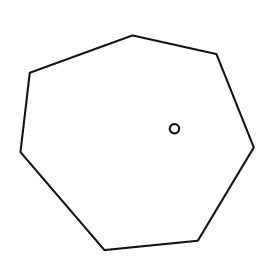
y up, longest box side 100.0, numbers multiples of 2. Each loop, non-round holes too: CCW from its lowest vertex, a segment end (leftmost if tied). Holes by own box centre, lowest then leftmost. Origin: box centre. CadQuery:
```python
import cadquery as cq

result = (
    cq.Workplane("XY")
    .moveTo(-14.0, -46.0)
    .lineTo(26.0, -42.0)
    .lineTo(50.0, -2.0)
    .lineTo(34.0, 38.0)
    .lineTo(-2.0, 46.0)
    .lineTo(-46.0, 30.0)
    .lineTo(-50.0, -4.0)
    .close()
    .moveTo(16.0, 6.0)
    .circle(2.0)
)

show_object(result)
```